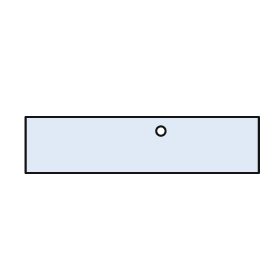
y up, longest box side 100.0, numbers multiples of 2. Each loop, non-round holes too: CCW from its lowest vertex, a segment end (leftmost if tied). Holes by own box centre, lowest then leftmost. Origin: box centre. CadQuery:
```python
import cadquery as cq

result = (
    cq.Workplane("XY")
    .moveTo(-50.0, -12.0)
    .lineTo(50.0, -12.0)
    .lineTo(50.0, 12.0)
    .lineTo(-50.0, 12.0)
    .close()
    .moveTo(8.0, 6.0)
    .circle(2.0)
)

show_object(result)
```